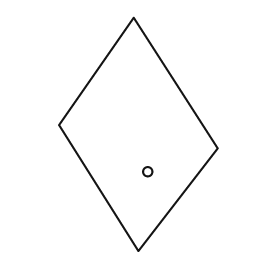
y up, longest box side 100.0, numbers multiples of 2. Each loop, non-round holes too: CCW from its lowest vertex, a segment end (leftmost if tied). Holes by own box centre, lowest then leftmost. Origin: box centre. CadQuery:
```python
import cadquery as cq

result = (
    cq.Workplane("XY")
    .moveTo(0.0, -50.0)
    .lineTo(34.0, -6.0)
    .lineTo(-2.0, 50.0)
    .lineTo(-34.0, 4.0)
    .close()
    .moveTo(4.0, -16.0)
    .circle(2.0)
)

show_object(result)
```